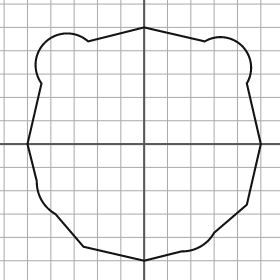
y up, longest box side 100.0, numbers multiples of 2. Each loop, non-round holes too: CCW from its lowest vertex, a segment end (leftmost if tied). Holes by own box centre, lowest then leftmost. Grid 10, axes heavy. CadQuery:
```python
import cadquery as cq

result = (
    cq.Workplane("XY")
    .moveTo(0.0, -50.0)
    .lineTo(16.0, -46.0)
    .threePointArc((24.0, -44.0), (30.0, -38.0))
    .lineTo(44.0, -26.0)
    .lineTo(50.0, 0.0)
    .lineTo(44.0, 26.0)
    .threePointArc((42.0, 42.0), (26.0, 44.0))
    .lineTo(0.0, 50.0)
    .lineTo(-24.0, 44.0)
    .threePointArc((-42.0, 44.0), (-44.0, 26.0))
    .lineTo(-50.0, 0.0)
    .lineTo(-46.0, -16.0)
    .threePointArc((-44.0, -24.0), (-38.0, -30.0))
    .lineTo(-26.0, -44.0)
    .close()
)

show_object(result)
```